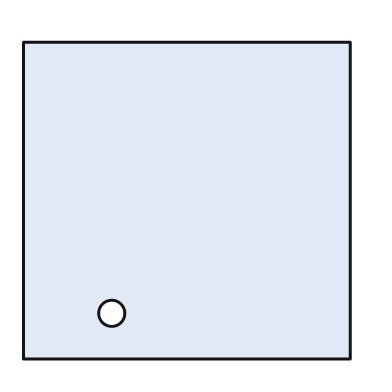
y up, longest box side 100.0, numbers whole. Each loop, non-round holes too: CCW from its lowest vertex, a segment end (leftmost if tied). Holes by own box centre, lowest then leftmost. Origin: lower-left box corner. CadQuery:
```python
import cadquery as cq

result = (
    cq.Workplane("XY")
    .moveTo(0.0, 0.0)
    .lineTo(100.0, 0.0)
    .lineTo(100.0, 97.0)
    .lineTo(0.0, 97.0)
    .close()
    .moveTo(27.0, 14.0)
    .circle(4.0)
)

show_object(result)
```